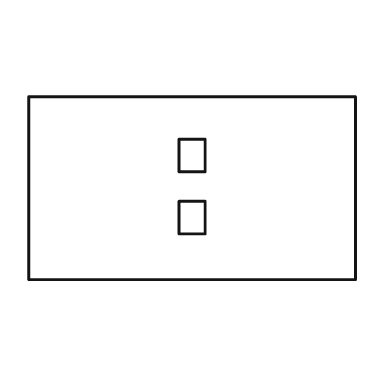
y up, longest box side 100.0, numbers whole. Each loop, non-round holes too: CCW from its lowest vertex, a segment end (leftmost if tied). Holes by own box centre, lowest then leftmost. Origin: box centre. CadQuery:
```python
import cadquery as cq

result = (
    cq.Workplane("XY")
    .moveTo(-50.0, -28.0)
    .lineTo(50.0, -28.0)
    .lineTo(50.0, 28.0)
    .lineTo(-50.0, 28.0)
    .close()
    .moveTo(-4.0, -14.0)
    .lineTo(4.0, -14.0)
    .lineTo(4.0, -4.0)
    .lineTo(-4.0, -4.0)
    .close()
    .moveTo(-4.0, 5.0)
    .lineTo(4.0, 5.0)
    .lineTo(4.0, 15.0)
    .lineTo(-4.0, 15.0)
    .close()
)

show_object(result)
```